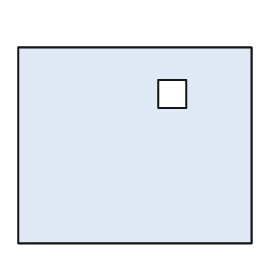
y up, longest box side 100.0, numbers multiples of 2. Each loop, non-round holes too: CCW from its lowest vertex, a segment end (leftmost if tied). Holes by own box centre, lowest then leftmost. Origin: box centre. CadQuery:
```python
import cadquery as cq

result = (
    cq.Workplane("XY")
    .moveTo(-50.0, -42.0)
    .lineTo(50.0, -42.0)
    .lineTo(50.0, 42.0)
    .lineTo(-50.0, 42.0)
    .close()
    .moveTo(10.0, 16.0)
    .lineTo(22.0, 16.0)
    .lineTo(22.0, 28.0)
    .lineTo(10.0, 28.0)
    .close()
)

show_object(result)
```